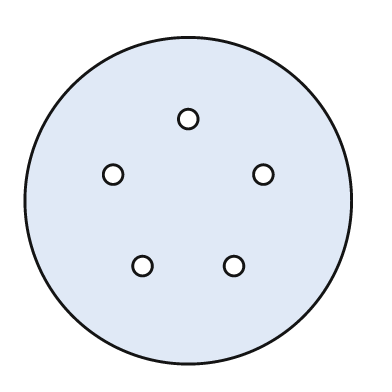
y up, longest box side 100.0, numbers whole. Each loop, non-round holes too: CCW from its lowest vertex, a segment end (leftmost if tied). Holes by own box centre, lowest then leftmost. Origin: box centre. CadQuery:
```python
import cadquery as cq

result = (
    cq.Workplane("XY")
    .moveTo(0.0, 0.0)
    .circle(50.0)
    .moveTo(-14.0, -20.0)
    .circle(3.0)
    .moveTo(14.0, -20.0)
    .circle(3.0)
    .moveTo(-23.0, 8.0)
    .circle(3.0)
    .moveTo(23.0, 8.0)
    .circle(3.0)
    .moveTo(0.0, 25.0)
    .circle(3.0)
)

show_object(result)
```